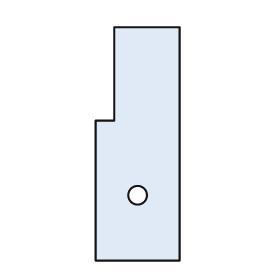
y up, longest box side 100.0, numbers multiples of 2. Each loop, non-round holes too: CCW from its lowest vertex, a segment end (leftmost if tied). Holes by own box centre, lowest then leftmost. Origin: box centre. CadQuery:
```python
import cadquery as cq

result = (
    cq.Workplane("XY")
    .moveTo(-18.0, -50.0)
    .lineTo(18.0, -50.0)
    .lineTo(18.0, 50.0)
    .lineTo(-10.0, 50.0)
    .lineTo(-10.0, 10.0)
    .lineTo(-18.0, 10.0)
    .close()
    .moveTo(0.0, -22.0)
    .circle(4.0)
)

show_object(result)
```